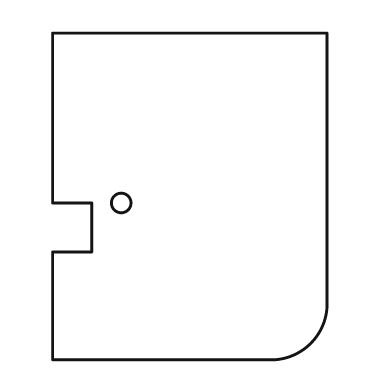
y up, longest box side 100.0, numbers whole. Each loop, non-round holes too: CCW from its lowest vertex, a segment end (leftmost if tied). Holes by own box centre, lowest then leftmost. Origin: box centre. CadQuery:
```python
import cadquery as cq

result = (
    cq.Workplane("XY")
    .moveTo(-42.0, -50.0)
    .lineTo(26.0, -50.0)
    .threePointArc((37.0, -45.0), (42.0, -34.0))
    .lineTo(42.0, 50.0)
    .lineTo(-42.0, 50.0)
    .lineTo(-42.0, -2.0)
    .lineTo(-30.0, -2.0)
    .lineTo(-30.0, -17.0)
    .lineTo(-42.0, -17.0)
    .close()
    .moveTo(-21.0, -2.0)
    .circle(3.0)
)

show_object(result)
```